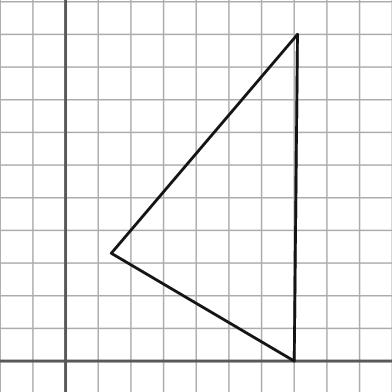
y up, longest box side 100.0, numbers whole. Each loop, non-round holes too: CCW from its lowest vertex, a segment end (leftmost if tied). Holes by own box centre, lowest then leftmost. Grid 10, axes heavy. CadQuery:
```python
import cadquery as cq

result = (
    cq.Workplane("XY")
    .moveTo(70.0, 0.0)
    .lineTo(71.0, 100.0)
    .lineTo(14.0, 33.0)
    .close()
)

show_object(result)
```